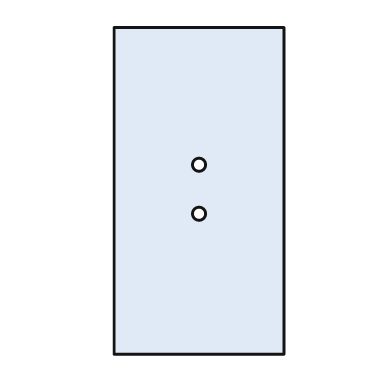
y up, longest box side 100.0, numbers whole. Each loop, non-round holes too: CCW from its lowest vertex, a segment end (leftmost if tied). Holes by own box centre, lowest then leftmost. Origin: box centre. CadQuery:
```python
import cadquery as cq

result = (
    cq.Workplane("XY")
    .moveTo(-26.0, -50.0)
    .lineTo(26.0, -50.0)
    .lineTo(26.0, 50.0)
    .lineTo(-26.0, 50.0)
    .close()
    .moveTo(0.0, -7.0)
    .circle(2.0)
    .moveTo(0.0, 8.0)
    .circle(2.0)
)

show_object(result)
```